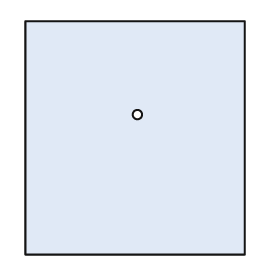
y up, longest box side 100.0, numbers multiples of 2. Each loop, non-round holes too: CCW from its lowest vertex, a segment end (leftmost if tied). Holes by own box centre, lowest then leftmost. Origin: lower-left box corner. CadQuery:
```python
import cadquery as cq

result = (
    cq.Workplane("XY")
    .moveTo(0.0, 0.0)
    .lineTo(94.0, 0.0)
    .lineTo(94.0, 100.0)
    .lineTo(0.0, 100.0)
    .close()
    .moveTo(48.0, 60.0)
    .circle(2.0)
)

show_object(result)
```